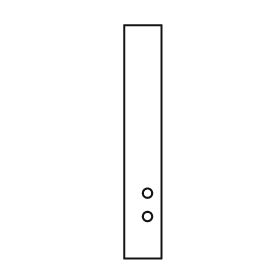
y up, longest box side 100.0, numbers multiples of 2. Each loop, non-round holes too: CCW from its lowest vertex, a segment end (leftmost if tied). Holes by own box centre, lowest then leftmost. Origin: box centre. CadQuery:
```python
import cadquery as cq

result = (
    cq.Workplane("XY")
    .moveTo(-8.0, -50.0)
    .lineTo(8.0, -50.0)
    .lineTo(8.0, 50.0)
    .lineTo(-8.0, 50.0)
    .close()
    .moveTo(2.0, -32.0)
    .circle(2.0)
    .moveTo(2.0, -22.0)
    .circle(2.0)
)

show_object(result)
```